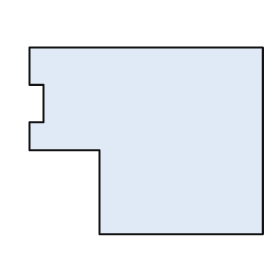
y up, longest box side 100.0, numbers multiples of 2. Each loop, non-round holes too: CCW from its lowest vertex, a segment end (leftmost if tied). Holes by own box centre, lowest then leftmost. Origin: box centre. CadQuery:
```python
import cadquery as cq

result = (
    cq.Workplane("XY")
    .moveTo(-20.0, -40.0)
    .lineTo(50.0, -40.0)
    .lineTo(50.0, 40.0)
    .lineTo(-50.0, 40.0)
    .lineTo(-50.0, 24.0)
    .lineTo(-44.0, 24.0)
    .lineTo(-44.0, 8.0)
    .lineTo(-50.0, 8.0)
    .lineTo(-50.0, -4.0)
    .lineTo(-20.0, -4.0)
    .close()
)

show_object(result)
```